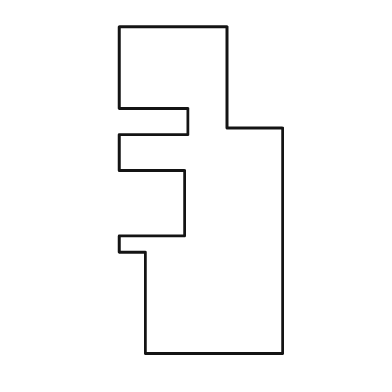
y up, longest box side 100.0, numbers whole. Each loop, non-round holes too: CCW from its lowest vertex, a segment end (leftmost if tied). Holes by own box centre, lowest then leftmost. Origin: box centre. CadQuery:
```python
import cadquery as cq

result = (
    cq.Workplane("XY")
    .moveTo(-17.0, -50.0)
    .lineTo(25.0, -50.0)
    .lineTo(25.0, 19.0)
    .lineTo(8.0, 19.0)
    .lineTo(8.0, 50.0)
    .lineTo(-25.0, 50.0)
    .lineTo(-25.0, 25.0)
    .lineTo(-4.0, 25.0)
    .lineTo(-4.0, 17.0)
    .lineTo(-25.0, 17.0)
    .lineTo(-25.0, 6.0)
    .lineTo(-5.0, 6.0)
    .lineTo(-5.0, -14.0)
    .lineTo(-25.0, -14.0)
    .lineTo(-25.0, -19.0)
    .lineTo(-17.0, -19.0)
    .close()
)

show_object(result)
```